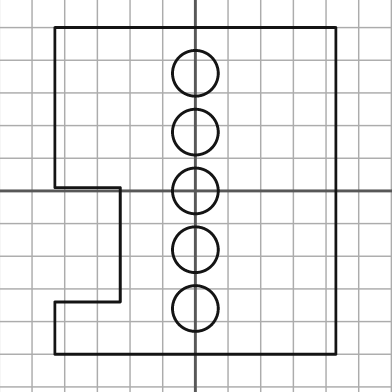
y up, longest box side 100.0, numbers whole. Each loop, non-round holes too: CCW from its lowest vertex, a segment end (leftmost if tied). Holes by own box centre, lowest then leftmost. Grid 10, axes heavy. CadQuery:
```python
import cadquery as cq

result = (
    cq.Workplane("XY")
    .moveTo(-43.0, -50.0)
    .lineTo(43.0, -50.0)
    .lineTo(43.0, 50.0)
    .lineTo(-43.0, 50.0)
    .lineTo(-43.0, 1.0)
    .lineTo(-23.0, 1.0)
    .lineTo(-23.0, -34.0)
    .lineTo(-43.0, -34.0)
    .close()
    .moveTo(0.0, -36.0)
    .circle(7.0)
    .moveTo(0.0, -18.0)
    .circle(7.0)
    .moveTo(0.0, 0.0)
    .circle(7.0)
    .moveTo(0.0, 18.0)
    .circle(7.0)
    .moveTo(0.0, 36.0)
    .circle(7.0)
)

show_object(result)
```